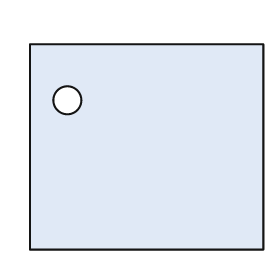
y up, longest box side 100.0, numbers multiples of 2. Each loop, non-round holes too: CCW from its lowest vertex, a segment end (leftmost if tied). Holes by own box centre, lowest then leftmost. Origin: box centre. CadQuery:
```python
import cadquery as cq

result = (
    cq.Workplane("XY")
    .moveTo(-50.0, -44.0)
    .lineTo(50.0, -44.0)
    .lineTo(50.0, 44.0)
    .lineTo(-50.0, 44.0)
    .close()
    .moveTo(-34.0, 20.0)
    .circle(6.0)
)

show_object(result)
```